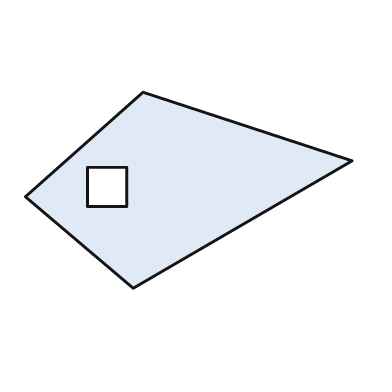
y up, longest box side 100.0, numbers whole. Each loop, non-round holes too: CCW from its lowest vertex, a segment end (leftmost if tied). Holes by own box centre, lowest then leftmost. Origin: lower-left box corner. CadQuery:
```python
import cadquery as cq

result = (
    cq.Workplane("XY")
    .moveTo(33.0, 0.0)
    .lineTo(100.0, 39.0)
    .lineTo(36.0, 60.0)
    .lineTo(0.0, 28.0)
    .close()
    .moveTo(19.0, 25.0)
    .lineTo(31.0, 25.0)
    .lineTo(31.0, 37.0)
    .lineTo(19.0, 37.0)
    .close()
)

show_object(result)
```